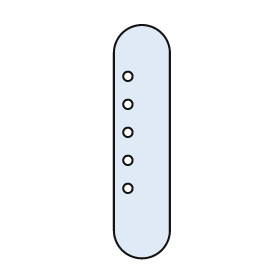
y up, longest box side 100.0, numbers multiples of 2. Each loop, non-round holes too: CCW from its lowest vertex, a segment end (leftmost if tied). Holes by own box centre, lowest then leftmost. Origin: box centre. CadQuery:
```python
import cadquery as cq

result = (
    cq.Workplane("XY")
    .moveTo(-12.0, -38.0)
    .threePointArc((0.0, -50.0), (12.0, -38.0))
    .lineTo(12.0, 38.0)
    .threePointArc((0.0, 50.0), (-12.0, 38.0))
    .close()
    .moveTo(-6.0, -20.0)
    .circle(2.0)
    .moveTo(-6.0, -8.0)
    .circle(2.0)
    .moveTo(-6.0, 4.0)
    .circle(2.0)
    .moveTo(-6.0, 16.0)
    .circle(2.0)
    .moveTo(-6.0, 28.0)
    .circle(2.0)
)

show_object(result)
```